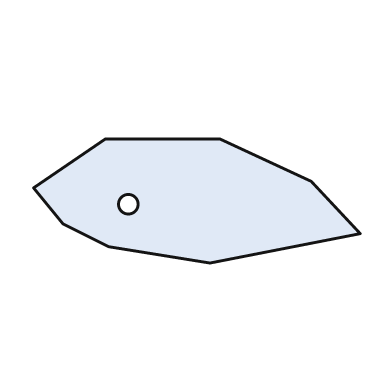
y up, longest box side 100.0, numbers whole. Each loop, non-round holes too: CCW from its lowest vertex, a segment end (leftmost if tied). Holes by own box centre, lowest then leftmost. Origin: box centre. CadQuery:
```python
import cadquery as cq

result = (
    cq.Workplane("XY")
    .moveTo(4.0, -19.0)
    .lineTo(50.0, -10.0)
    .lineTo(35.0, 6.0)
    .lineTo(7.0, 19.0)
    .lineTo(-28.0, 19.0)
    .lineTo(-50.0, 4.0)
    .lineTo(-41.0, -7.0)
    .lineTo(-27.0, -14.0)
    .close()
    .moveTo(-21.0, -1.0)
    .circle(3.0)
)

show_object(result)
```